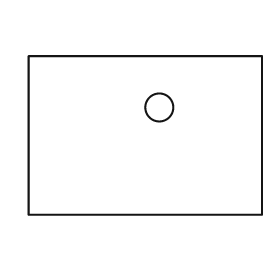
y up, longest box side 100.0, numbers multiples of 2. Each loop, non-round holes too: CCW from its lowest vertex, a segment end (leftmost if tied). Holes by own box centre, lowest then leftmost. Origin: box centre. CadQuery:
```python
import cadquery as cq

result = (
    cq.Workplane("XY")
    .moveTo(-50.0, -34.0)
    .lineTo(50.0, -34.0)
    .lineTo(50.0, 34.0)
    .lineTo(-50.0, 34.0)
    .close()
    .moveTo(6.0, 12.0)
    .circle(6.0)
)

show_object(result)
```